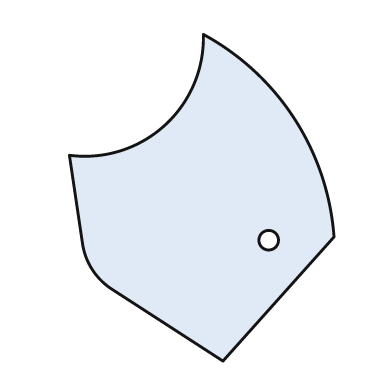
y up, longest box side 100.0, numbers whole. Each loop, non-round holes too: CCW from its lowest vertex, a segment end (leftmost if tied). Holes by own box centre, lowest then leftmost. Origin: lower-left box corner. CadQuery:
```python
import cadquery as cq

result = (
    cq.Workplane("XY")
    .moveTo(47.0, 0.0)
    .lineTo(81.0, 38.0)
    .threePointArc((69.0, 74.0), (41.0, 100.0))
    .threePointArc((29.0, 72.0), (0.0, 63.0))
    .lineTo(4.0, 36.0)
    .threePointArc((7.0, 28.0), (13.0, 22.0))
    .close()
    .moveTo(61.0, 37.0)
    .circle(3.0)
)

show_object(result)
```